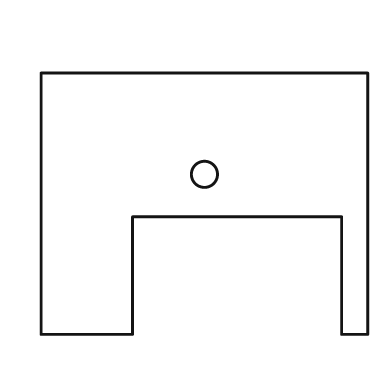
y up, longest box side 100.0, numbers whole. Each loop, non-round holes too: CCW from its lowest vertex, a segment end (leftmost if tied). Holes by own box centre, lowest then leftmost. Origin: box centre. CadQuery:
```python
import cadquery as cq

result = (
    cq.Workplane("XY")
    .moveTo(-50.0, -40.0)
    .lineTo(-22.0, -40.0)
    .lineTo(-22.0, -4.0)
    .lineTo(42.0, -4.0)
    .lineTo(42.0, -40.0)
    .lineTo(50.0, -40.0)
    .lineTo(50.0, 40.0)
    .lineTo(-50.0, 40.0)
    .close()
    .moveTo(0.0, 9.0)
    .circle(4.0)
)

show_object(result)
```